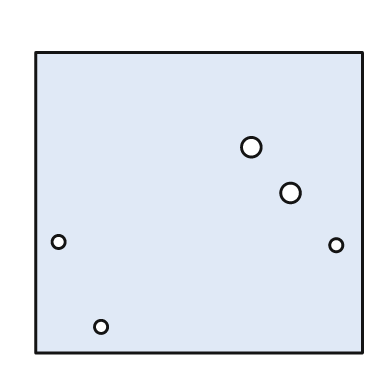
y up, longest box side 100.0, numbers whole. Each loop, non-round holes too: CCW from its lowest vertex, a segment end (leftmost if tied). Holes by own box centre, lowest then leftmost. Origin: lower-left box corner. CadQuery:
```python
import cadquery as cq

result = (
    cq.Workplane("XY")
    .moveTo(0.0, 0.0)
    .lineTo(100.0, 0.0)
    .lineTo(100.0, 92.0)
    .lineTo(0.0, 92.0)
    .close()
    .moveTo(20.0, 8.0)
    .circle(2.0)
    .moveTo(92.0, 33.0)
    .circle(2.0)
    .moveTo(7.0, 34.0)
    .circle(2.0)
    .moveTo(78.0, 49.0)
    .circle(3.0)
    .moveTo(66.0, 63.0)
    .circle(3.0)
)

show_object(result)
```